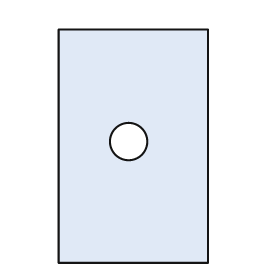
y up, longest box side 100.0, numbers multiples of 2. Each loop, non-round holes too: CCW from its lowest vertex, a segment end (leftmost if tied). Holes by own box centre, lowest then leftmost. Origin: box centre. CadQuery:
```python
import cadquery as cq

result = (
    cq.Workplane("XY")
    .moveTo(-32.0, -50.0)
    .lineTo(32.0, -50.0)
    .lineTo(32.0, 50.0)
    .lineTo(-32.0, 50.0)
    .close()
    .moveTo(-2.0, 2.0)
    .circle(8.0)
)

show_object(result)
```